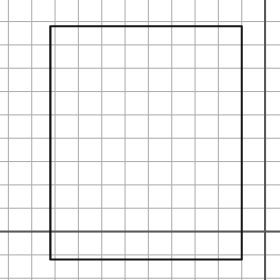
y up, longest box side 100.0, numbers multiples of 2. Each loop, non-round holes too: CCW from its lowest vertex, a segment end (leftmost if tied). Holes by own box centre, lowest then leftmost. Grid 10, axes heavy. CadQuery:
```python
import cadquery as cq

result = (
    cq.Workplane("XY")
    .moveTo(-92.0, -12.0)
    .lineTo(-10.0, -12.0)
    .lineTo(-10.0, 88.0)
    .lineTo(-92.0, 88.0)
    .close()
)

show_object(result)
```